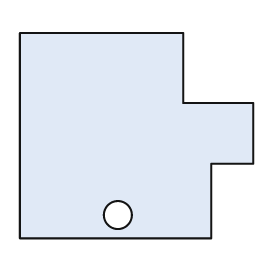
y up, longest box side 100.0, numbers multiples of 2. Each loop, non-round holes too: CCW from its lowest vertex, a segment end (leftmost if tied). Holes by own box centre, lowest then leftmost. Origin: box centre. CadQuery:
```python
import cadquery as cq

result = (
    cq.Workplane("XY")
    .moveTo(-50.0, -44.0)
    .lineTo(32.0, -44.0)
    .lineTo(32.0, -12.0)
    .lineTo(50.0, -12.0)
    .lineTo(50.0, 14.0)
    .lineTo(20.0, 14.0)
    .lineTo(20.0, 44.0)
    .lineTo(-50.0, 44.0)
    .close()
    .moveTo(-8.0, -34.0)
    .circle(6.0)
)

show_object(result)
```